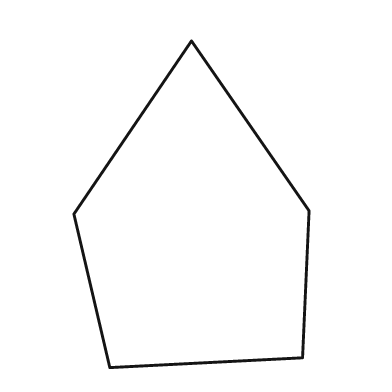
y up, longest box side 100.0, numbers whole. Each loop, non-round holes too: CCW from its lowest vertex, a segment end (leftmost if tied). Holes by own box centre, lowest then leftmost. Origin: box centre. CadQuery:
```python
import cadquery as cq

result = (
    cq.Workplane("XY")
    .moveTo(-25.0, -50.0)
    .lineTo(34.0, -47.0)
    .lineTo(36.0, -2.0)
    .lineTo(0.0, 50.0)
    .lineTo(-36.0, -3.0)
    .close()
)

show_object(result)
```